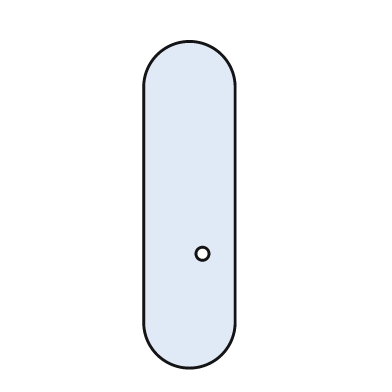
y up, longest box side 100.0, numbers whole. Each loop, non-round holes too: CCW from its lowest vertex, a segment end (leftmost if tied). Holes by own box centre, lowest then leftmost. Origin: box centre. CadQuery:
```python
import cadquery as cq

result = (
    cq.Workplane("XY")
    .moveTo(-14.0, -36.0)
    .threePointArc((0.0, -50.0), (14.0, -36.0))
    .lineTo(14.0, 36.0)
    .threePointArc((0.0, 50.0), (-14.0, 36.0))
    .close()
    .moveTo(4.0, -15.0)
    .circle(2.0)
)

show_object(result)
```